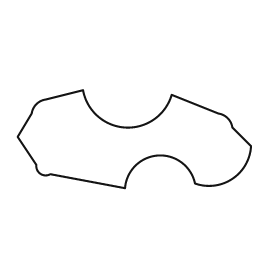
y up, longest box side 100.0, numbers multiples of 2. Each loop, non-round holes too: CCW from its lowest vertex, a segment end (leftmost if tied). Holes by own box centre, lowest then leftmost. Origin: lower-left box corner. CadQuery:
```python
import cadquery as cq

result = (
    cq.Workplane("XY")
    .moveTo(46.0, 0.0)
    .threePointArc((60.0, 14.0), (76.0, 2.0))
    .threePointArc((92.0, 4.0), (100.0, 18.0))
    .lineTo(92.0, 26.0)
    .threePointArc((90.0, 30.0), (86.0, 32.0))
    .lineTo(66.0, 40.0)
    .threePointArc((46.0, 26.0), (28.0, 42.0))
    .lineTo(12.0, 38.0)
    .threePointArc((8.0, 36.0), (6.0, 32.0))
    .lineTo(0.0, 22.0)
    .lineTo(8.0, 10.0)
    .threePointArc((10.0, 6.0), (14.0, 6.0))
    .close()
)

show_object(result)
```